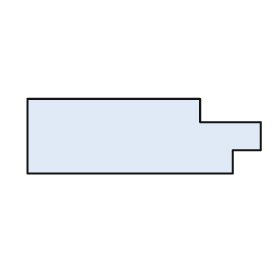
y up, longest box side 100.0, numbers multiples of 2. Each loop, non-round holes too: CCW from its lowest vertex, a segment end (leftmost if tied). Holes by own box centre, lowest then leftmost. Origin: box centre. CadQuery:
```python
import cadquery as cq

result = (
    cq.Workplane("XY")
    .moveTo(-50.0, -16.0)
    .lineTo(38.0, -16.0)
    .lineTo(38.0, -6.0)
    .lineTo(50.0, -6.0)
    .lineTo(50.0, 6.0)
    .lineTo(24.0, 6.0)
    .lineTo(24.0, 16.0)
    .lineTo(-50.0, 16.0)
    .close()
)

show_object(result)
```